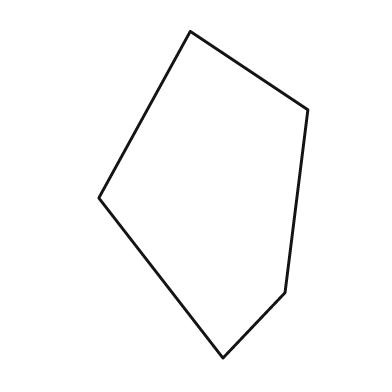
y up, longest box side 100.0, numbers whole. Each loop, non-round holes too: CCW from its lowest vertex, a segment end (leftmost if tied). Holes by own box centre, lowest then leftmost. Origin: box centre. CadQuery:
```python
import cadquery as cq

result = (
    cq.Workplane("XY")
    .moveTo(6.0, -50.0)
    .lineTo(25.0, -30.0)
    .lineTo(32.0, 26.0)
    .lineTo(-4.0, 50.0)
    .lineTo(-32.0, -1.0)
    .close()
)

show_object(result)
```